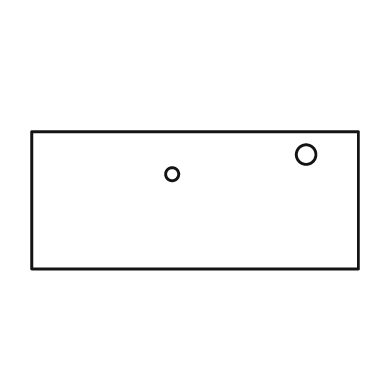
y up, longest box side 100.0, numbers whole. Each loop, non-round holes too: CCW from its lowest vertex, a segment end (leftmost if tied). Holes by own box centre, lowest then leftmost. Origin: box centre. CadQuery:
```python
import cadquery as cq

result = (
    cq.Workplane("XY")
    .moveTo(-50.0, -21.0)
    .lineTo(50.0, -21.0)
    .lineTo(50.0, 21.0)
    .lineTo(-50.0, 21.0)
    .close()
    .moveTo(-7.0, 8.0)
    .circle(2.0)
    .moveTo(34.0, 14.0)
    .circle(3.0)
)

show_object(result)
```